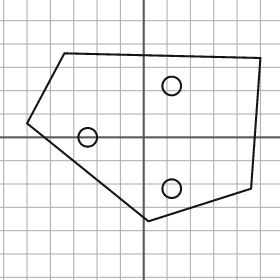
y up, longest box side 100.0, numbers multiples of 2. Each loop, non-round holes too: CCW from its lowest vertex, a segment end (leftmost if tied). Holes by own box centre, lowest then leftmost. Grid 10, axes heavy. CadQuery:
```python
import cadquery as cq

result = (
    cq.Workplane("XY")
    .moveTo(2.0, -36.0)
    .lineTo(46.0, -22.0)
    .lineTo(50.0, 34.0)
    .lineTo(-34.0, 36.0)
    .lineTo(-50.0, 6.0)
    .close()
    .moveTo(12.0, -22.0)
    .circle(4.0)
    .moveTo(-24.0, 0.0)
    .circle(4.0)
    .moveTo(12.0, 22.0)
    .circle(4.0)
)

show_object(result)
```